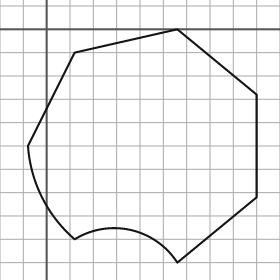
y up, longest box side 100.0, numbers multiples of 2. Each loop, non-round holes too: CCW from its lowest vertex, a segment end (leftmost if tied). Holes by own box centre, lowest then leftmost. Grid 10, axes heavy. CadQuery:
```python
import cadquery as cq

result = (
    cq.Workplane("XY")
    .moveTo(56.0, -100.0)
    .lineTo(90.0, -72.0)
    .lineTo(90.0, -28.0)
    .lineTo(56.0, 0.0)
    .lineTo(12.0, -10.0)
    .lineTo(-8.0, -50.0)
    .threePointArc((-2.0, -72.0), (12.0, -90.0))
    .threePointArc((36.0, -86.0), (56.0, -100.0))
    .close()
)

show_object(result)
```